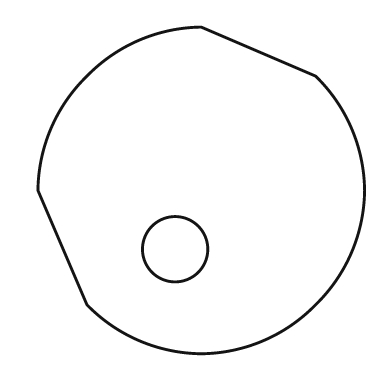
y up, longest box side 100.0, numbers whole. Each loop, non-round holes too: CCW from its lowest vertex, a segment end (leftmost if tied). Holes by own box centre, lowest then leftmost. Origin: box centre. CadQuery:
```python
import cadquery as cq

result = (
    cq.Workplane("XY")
    .moveTo(0.0, -50.0)
    .threePointArc((19.0, -46.0), (35.0, -35.0))
    .threePointArc((46.0, -19.0), (50.0, 0.0))
    .threePointArc((46.0, 19.0), (35.0, 35.0))
    .lineTo(0.0, 50.0)
    .threePointArc((-19.0, 46.0), (-35.0, 35.0))
    .threePointArc((-46.0, 19.0), (-50.0, 0.0))
    .lineTo(-35.0, -35.0)
    .threePointArc((-19.0, -46.0), (0.0, -50.0))
    .close()
    .moveTo(-8.0, -18.0)
    .circle(10.0)
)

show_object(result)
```